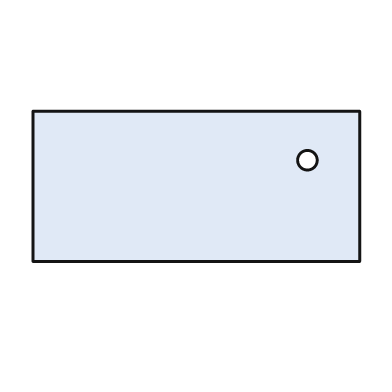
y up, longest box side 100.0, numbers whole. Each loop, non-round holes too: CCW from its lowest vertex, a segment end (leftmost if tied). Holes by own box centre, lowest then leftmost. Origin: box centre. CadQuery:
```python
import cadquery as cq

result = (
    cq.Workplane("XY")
    .moveTo(-50.0, -23.0)
    .lineTo(50.0, -23.0)
    .lineTo(50.0, 23.0)
    .lineTo(-50.0, 23.0)
    .close()
    .moveTo(34.0, 8.0)
    .circle(3.0)
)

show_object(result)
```